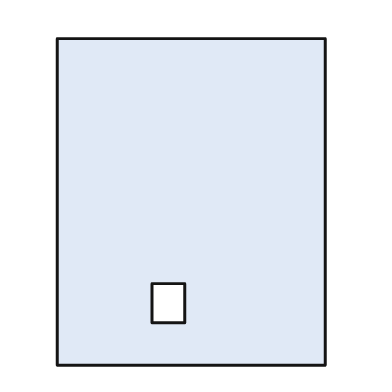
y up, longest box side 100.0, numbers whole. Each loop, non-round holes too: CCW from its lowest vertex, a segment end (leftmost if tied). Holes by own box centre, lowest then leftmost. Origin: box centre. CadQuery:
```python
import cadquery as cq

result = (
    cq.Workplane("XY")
    .moveTo(-41.0, -50.0)
    .lineTo(41.0, -50.0)
    .lineTo(41.0, 50.0)
    .lineTo(-41.0, 50.0)
    .close()
    .moveTo(-12.0, -37.0)
    .lineTo(-2.0, -37.0)
    .lineTo(-2.0, -25.0)
    .lineTo(-12.0, -25.0)
    .close()
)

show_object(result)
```